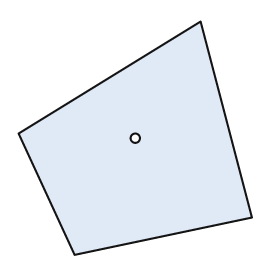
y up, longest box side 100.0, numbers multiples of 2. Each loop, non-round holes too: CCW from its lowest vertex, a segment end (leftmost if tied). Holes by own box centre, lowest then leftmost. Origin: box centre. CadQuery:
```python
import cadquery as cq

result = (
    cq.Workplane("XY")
    .moveTo(-26.0, -50.0)
    .lineTo(50.0, -34.0)
    .lineTo(28.0, 50.0)
    .lineTo(-50.0, 2.0)
    .close()
    .moveTo(0.0, 0.0)
    .circle(2.0)
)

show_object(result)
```